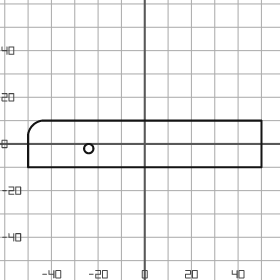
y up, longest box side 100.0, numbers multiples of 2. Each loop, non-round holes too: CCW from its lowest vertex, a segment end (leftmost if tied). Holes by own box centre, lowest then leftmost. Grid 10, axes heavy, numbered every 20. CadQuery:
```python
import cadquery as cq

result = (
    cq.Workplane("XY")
    .moveTo(-50.0, -10.0)
    .lineTo(50.0, -10.0)
    .lineTo(50.0, 10.0)
    .lineTo(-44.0, 10.0)
    .threePointArc((-48.0, 8.0), (-50.0, 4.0))
    .close()
    .moveTo(-24.0, -2.0)
    .circle(2.0)
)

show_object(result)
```